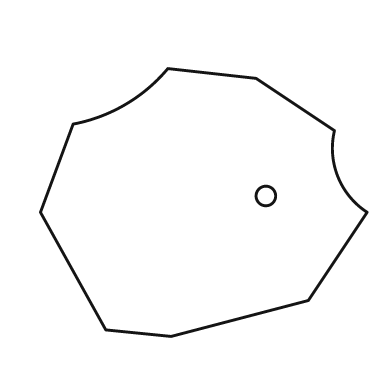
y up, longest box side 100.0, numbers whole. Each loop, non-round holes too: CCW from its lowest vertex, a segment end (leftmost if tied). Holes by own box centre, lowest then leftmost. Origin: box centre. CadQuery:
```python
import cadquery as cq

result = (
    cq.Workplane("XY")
    .moveTo(-10.0, -41.0)
    .lineTo(32.0, -30.0)
    .lineTo(50.0, -3.0)
    .threePointArc((41.0, 8.0), (40.0, 22.0))
    .lineTo(16.0, 38.0)
    .lineTo(-11.0, 41.0)
    .threePointArc((-24.0, 30.0), (-40.0, 24.0))
    .lineTo(-50.0, -3.0)
    .lineTo(-30.0, -39.0)
    .close()
    .moveTo(19.0, 2.0)
    .circle(3.0)
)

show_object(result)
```